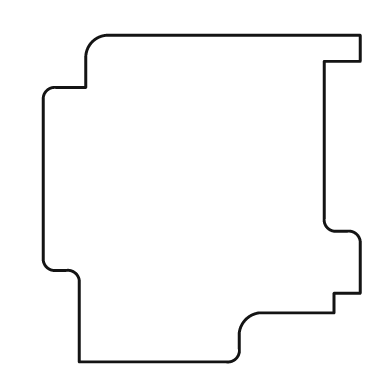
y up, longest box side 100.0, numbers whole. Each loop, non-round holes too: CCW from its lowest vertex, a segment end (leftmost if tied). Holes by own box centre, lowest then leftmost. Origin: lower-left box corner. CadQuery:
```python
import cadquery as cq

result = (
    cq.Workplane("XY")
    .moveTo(11.0, 0.0)
    .lineTo(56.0, 0.0)
    .threePointArc((59.0, 1.0), (60.0, 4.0))
    .lineTo(60.0, 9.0)
    .threePointArc((62.0, 13.0), (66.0, 15.0))
    .lineTo(89.0, 15.0)
    .lineTo(89.0, 21.0)
    .lineTo(97.0, 21.0)
    .lineTo(97.0, 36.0)
    .threePointArc((96.0, 39.0), (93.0, 40.0))
    .lineTo(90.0, 40.0)
    .threePointArc((87.0, 41.0), (86.0, 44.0))
    .lineTo(86.0, 92.0)
    .lineTo(97.0, 92.0)
    .lineTo(97.0, 100.0)
    .lineTo(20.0, 100.0)
    .threePointArc((15.0, 98.0), (13.0, 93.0))
    .lineTo(13.0, 84.0)
    .lineTo(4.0, 84.0)
    .threePointArc((1.0, 83.0), (0.0, 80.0))
    .lineTo(0.0, 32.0)
    .threePointArc((1.0, 29.0), (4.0, 28.0))
    .lineTo(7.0, 28.0)
    .threePointArc((10.0, 27.0), (11.0, 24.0))
    .close()
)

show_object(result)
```